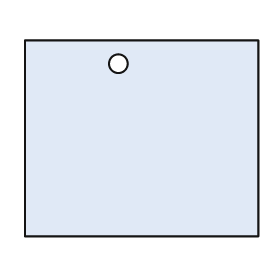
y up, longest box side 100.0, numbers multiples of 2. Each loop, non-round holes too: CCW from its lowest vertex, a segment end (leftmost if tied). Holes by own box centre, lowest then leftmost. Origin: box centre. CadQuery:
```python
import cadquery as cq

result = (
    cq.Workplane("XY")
    .moveTo(-50.0, -42.0)
    .lineTo(50.0, -42.0)
    .lineTo(50.0, 42.0)
    .lineTo(-50.0, 42.0)
    .close()
    .moveTo(-10.0, 32.0)
    .circle(4.0)
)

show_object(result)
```